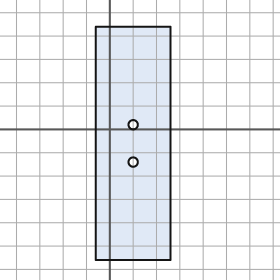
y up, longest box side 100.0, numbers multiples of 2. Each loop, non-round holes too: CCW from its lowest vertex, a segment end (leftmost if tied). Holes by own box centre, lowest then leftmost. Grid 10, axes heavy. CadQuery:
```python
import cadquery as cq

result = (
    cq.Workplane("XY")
    .moveTo(-6.0, -56.0)
    .lineTo(26.0, -56.0)
    .lineTo(26.0, 44.0)
    .lineTo(-6.0, 44.0)
    .close()
    .moveTo(10.0, -14.0)
    .circle(2.0)
    .moveTo(10.0, 2.0)
    .circle(2.0)
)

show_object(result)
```